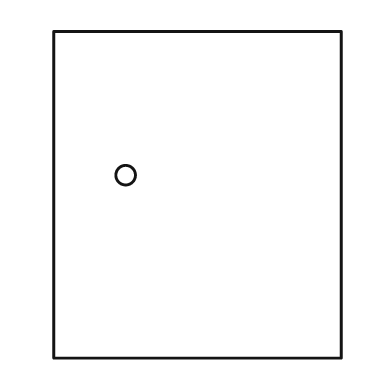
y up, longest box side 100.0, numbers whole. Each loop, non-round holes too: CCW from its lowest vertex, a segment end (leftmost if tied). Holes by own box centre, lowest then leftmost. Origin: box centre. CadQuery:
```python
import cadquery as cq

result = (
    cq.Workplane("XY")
    .moveTo(-44.0, -50.0)
    .lineTo(44.0, -50.0)
    .lineTo(44.0, 50.0)
    .lineTo(-44.0, 50.0)
    .close()
    .moveTo(-22.0, 6.0)
    .circle(3.0)
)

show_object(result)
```